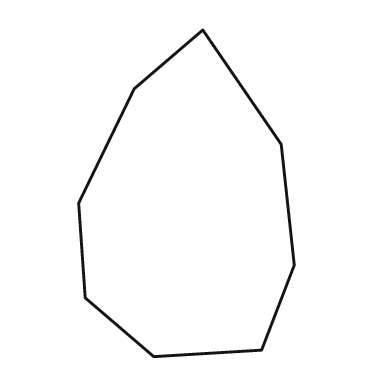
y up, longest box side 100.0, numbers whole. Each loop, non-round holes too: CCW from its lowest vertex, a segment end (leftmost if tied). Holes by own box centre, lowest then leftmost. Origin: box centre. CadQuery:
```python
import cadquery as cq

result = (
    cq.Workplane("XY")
    .moveTo(-10.0, -50.0)
    .lineTo(23.0, -48.0)
    .lineTo(33.0, -22.0)
    .lineTo(29.0, 15.0)
    .lineTo(5.0, 50.0)
    .lineTo(-16.0, 32.0)
    .lineTo(-33.0, -3.0)
    .lineTo(-31.0, -32.0)
    .close()
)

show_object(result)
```